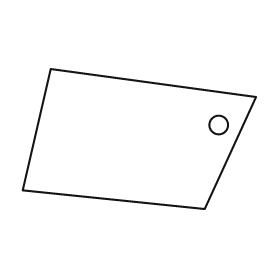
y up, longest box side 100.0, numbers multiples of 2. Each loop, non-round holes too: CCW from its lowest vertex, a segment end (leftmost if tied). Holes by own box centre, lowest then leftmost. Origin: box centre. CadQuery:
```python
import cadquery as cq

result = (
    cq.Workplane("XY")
    .moveTo(28.0, -30.0)
    .lineTo(50.0, 18.0)
    .lineTo(-38.0, 30.0)
    .lineTo(-50.0, -22.0)
    .close()
    .moveTo(34.0, 6.0)
    .circle(4.0)
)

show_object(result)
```